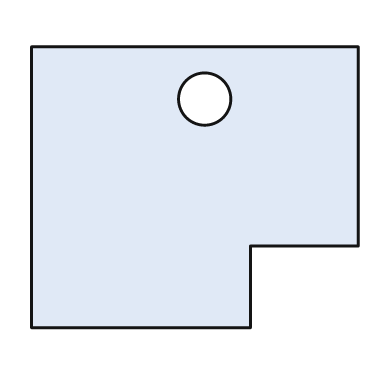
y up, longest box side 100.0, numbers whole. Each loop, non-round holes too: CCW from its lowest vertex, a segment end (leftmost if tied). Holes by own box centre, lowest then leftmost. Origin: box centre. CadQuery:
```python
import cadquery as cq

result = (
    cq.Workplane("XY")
    .moveTo(-50.0, -43.0)
    .lineTo(17.0, -43.0)
    .lineTo(17.0, -18.0)
    .lineTo(50.0, -18.0)
    .lineTo(50.0, 43.0)
    .lineTo(-50.0, 43.0)
    .close()
    .moveTo(3.0, 27.0)
    .circle(8.0)
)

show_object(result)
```